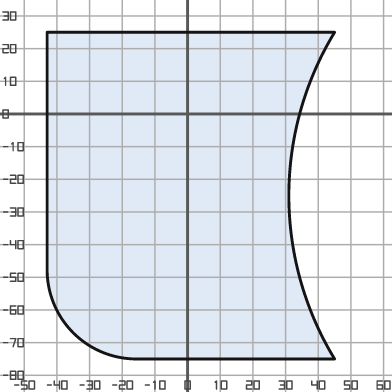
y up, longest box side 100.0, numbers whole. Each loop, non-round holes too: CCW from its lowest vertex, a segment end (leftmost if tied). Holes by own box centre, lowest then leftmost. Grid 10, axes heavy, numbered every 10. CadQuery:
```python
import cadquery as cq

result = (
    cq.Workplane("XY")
    .moveTo(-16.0, -75.0)
    .lineTo(45.0, -75.0)
    .threePointArc((31.0, -25.0), (45.0, 25.0))
    .lineTo(-43.0, 25.0)
    .lineTo(-43.0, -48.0)
    .threePointArc((-35.0, -67.0), (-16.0, -75.0))
    .close()
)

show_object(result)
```